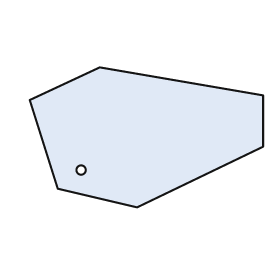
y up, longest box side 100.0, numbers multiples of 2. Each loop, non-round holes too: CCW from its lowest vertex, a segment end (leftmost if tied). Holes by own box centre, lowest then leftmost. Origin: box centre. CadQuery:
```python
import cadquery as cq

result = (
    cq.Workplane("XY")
    .moveTo(-4.0, -30.0)
    .lineTo(50.0, -4.0)
    .lineTo(50.0, 18.0)
    .lineTo(-20.0, 30.0)
    .lineTo(-50.0, 16.0)
    .lineTo(-38.0, -22.0)
    .close()
    .moveTo(-28.0, -14.0)
    .circle(2.0)
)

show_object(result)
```